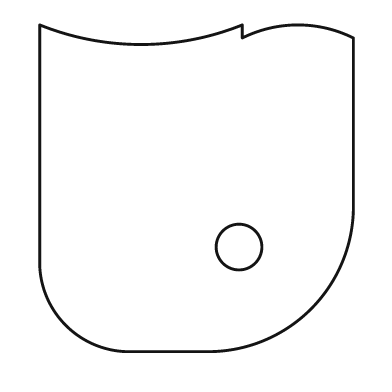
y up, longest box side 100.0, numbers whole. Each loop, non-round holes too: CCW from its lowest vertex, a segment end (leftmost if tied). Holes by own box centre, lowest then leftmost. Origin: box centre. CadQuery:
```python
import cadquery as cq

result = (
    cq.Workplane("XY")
    .moveTo(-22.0, -50.0)
    .lineTo(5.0, -50.0)
    .threePointArc((35.0, -37.0), (48.0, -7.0))
    .lineTo(48.0, 46.0)
    .threePointArc((31.0, 50.0), (14.0, 46.0))
    .lineTo(14.0, 50.0)
    .threePointArc((-17.0, 44.0), (-48.0, 50.0))
    .lineTo(-48.0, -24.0)
    .threePointArc((-40.0, -42.0), (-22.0, -50.0))
    .close()
    .moveTo(13.0, -18.0)
    .circle(7.0)
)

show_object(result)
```